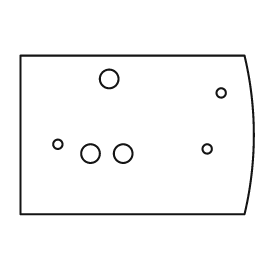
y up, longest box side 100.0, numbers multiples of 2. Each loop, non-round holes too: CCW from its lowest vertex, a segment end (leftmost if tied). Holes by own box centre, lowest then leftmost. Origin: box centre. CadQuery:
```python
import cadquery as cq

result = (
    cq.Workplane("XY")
    .moveTo(-50.0, -34.0)
    .lineTo(46.0, -34.0)
    .threePointArc((50.0, 0.0), (46.0, 34.0))
    .lineTo(-50.0, 34.0)
    .close()
    .moveTo(-20.0, -8.0)
    .circle(4.0)
    .moveTo(-6.0, -8.0)
    .circle(4.0)
    .moveTo(30.0, -6.0)
    .circle(2.0)
    .moveTo(-34.0, -4.0)
    .circle(2.0)
    .moveTo(36.0, 18.0)
    .circle(2.0)
    .moveTo(-12.0, 24.0)
    .circle(4.0)
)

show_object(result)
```